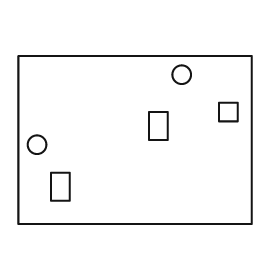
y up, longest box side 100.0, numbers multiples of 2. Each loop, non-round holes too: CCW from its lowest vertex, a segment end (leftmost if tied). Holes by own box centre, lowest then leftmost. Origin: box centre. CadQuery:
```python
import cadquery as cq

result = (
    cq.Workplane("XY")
    .moveTo(-50.0, -36.0)
    .lineTo(50.0, -36.0)
    .lineTo(50.0, 36.0)
    .lineTo(-50.0, 36.0)
    .close()
    .moveTo(-36.0, -26.0)
    .lineTo(-28.0, -26.0)
    .lineTo(-28.0, -14.0)
    .lineTo(-36.0, -14.0)
    .close()
    .moveTo(-42.0, -2.0)
    .circle(4.0)
    .moveTo(6.0, 0.0)
    .lineTo(14.0, 0.0)
    .lineTo(14.0, 12.0)
    .lineTo(6.0, 12.0)
    .close()
    .moveTo(36.0, 8.0)
    .lineTo(44.0, 8.0)
    .lineTo(44.0, 16.0)
    .lineTo(36.0, 16.0)
    .close()
    .moveTo(20.0, 28.0)
    .circle(4.0)
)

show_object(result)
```